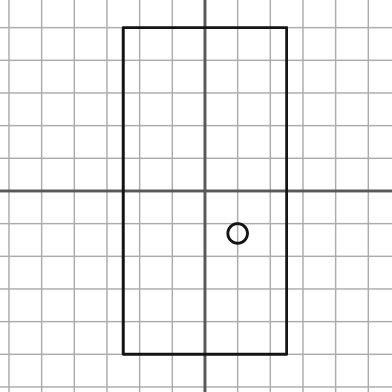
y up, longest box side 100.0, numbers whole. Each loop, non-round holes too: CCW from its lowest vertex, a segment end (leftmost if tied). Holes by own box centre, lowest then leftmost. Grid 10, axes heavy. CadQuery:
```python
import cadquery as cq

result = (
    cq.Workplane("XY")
    .moveTo(-25.0, -50.0)
    .lineTo(25.0, -50.0)
    .lineTo(25.0, 50.0)
    .lineTo(-25.0, 50.0)
    .close()
    .moveTo(10.0, -13.0)
    .circle(3.0)
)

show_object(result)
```